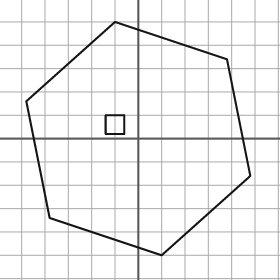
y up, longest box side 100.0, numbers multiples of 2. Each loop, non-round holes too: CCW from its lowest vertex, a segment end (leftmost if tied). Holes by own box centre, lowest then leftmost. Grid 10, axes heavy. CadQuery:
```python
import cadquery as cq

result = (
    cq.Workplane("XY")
    .moveTo(10.0, -50.0)
    .lineTo(48.0, -16.0)
    .lineTo(38.0, 34.0)
    .lineTo(-10.0, 50.0)
    .lineTo(-48.0, 16.0)
    .lineTo(-38.0, -34.0)
    .close()
    .moveTo(-14.0, 2.0)
    .lineTo(-6.0, 2.0)
    .lineTo(-6.0, 10.0)
    .lineTo(-14.0, 10.0)
    .close()
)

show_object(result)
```